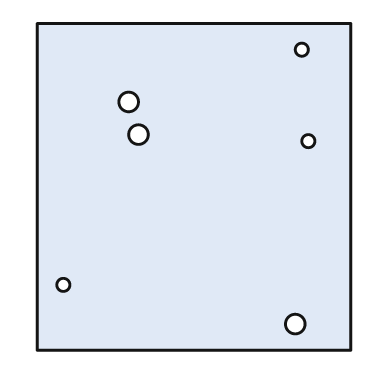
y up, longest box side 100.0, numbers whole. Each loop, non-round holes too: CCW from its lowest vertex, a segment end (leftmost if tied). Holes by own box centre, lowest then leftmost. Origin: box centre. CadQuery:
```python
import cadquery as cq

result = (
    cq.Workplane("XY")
    .moveTo(-48.0, -50.0)
    .lineTo(48.0, -50.0)
    .lineTo(48.0, 50.0)
    .lineTo(-48.0, 50.0)
    .close()
    .moveTo(31.0, -42.0)
    .circle(3.0)
    .moveTo(-40.0, -30.0)
    .circle(2.0)
    .moveTo(35.0, 14.0)
    .circle(2.0)
    .moveTo(-17.0, 16.0)
    .circle(3.0)
    .moveTo(-20.0, 26.0)
    .circle(3.0)
    .moveTo(33.0, 42.0)
    .circle(2.0)
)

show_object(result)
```